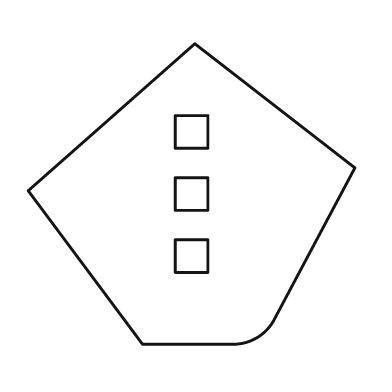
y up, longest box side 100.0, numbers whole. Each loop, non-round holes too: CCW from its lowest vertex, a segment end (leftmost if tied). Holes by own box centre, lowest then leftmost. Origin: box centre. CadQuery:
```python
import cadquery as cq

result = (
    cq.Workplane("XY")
    .moveTo(-15.0, -46.0)
    .lineTo(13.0, -46.0)
    .threePointArc((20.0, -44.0), (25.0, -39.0))
    .lineTo(50.0, 8.0)
    .lineTo(1.0, 46.0)
    .lineTo(-50.0, 1.0)
    .close()
    .moveTo(-5.0, -24.0)
    .lineTo(5.0, -24.0)
    .lineTo(5.0, -14.0)
    .lineTo(-5.0, -14.0)
    .close()
    .moveTo(-5.0, -5.0)
    .lineTo(5.0, -5.0)
    .lineTo(5.0, 5.0)
    .lineTo(-5.0, 5.0)
    .close()
    .moveTo(-5.0, 14.0)
    .lineTo(5.0, 14.0)
    .lineTo(5.0, 24.0)
    .lineTo(-5.0, 24.0)
    .close()
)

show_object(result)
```